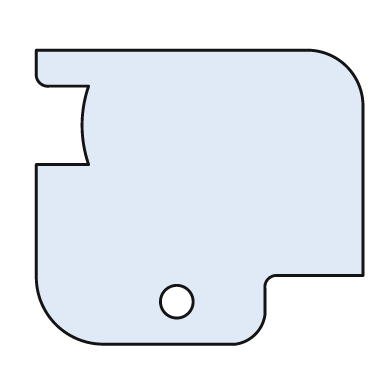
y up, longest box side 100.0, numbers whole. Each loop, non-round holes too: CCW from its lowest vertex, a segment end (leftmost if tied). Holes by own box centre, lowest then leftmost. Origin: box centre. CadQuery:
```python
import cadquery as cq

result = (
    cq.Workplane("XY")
    .moveTo(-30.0, -45.0)
    .lineTo(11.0, -45.0)
    .threePointArc((17.0, -42.0), (20.0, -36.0))
    .lineTo(20.0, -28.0)
    .threePointArc((21.0, -25.0), (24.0, -24.0))
    .lineTo(50.0, -24.0)
    .lineTo(50.0, 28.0)
    .threePointArc((45.0, 40.0), (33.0, 45.0))
    .lineTo(-50.0, 45.0)
    .lineTo(-50.0, 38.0)
    .threePointArc((-49.0, 35.0), (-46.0, 34.0))
    .lineTo(-34.0, 34.0)
    .threePointArc((-36.0, 22.0), (-34.0, 10.0))
    .lineTo(-50.0, 10.0)
    .lineTo(-50.0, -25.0)
    .threePointArc((-44.0, -39.0), (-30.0, -45.0))
    .close()
    .moveTo(-7.0, -32.0)
    .circle(5.0)
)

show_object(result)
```